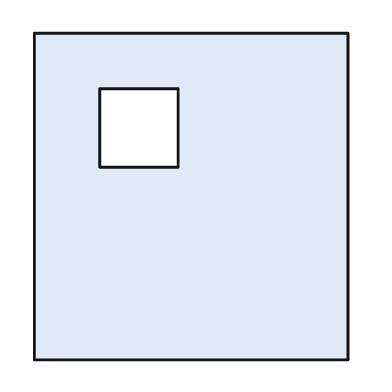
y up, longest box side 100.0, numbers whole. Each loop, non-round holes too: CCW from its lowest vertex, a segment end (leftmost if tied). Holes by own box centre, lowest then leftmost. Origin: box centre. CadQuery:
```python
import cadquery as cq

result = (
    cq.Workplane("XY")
    .moveTo(-48.0, -50.0)
    .lineTo(48.0, -50.0)
    .lineTo(48.0, 50.0)
    .lineTo(-48.0, 50.0)
    .close()
    .moveTo(-28.0, 9.0)
    .lineTo(-4.0, 9.0)
    .lineTo(-4.0, 33.0)
    .lineTo(-28.0, 33.0)
    .close()
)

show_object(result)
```